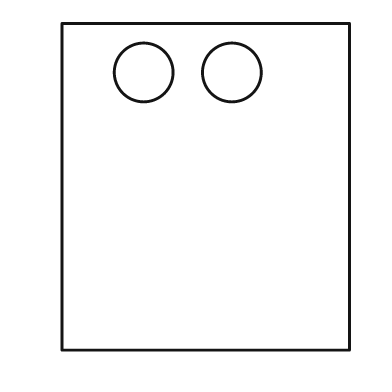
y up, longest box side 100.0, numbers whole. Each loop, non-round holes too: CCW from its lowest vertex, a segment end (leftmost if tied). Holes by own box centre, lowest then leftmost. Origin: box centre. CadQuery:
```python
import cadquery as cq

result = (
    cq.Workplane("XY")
    .moveTo(-44.0, -50.0)
    .lineTo(44.0, -50.0)
    .lineTo(44.0, 50.0)
    .lineTo(-44.0, 50.0)
    .close()
    .moveTo(-19.0, 35.0)
    .circle(9.0)
    .moveTo(8.0, 35.0)
    .circle(9.0)
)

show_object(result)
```